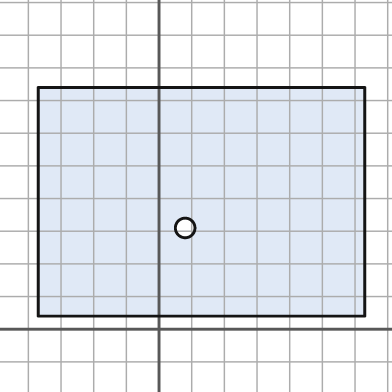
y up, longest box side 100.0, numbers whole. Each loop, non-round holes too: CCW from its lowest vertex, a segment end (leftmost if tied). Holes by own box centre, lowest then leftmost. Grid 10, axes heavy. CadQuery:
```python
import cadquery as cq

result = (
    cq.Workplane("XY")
    .moveTo(-37.0, 4.0)
    .lineTo(63.0, 4.0)
    .lineTo(63.0, 74.0)
    .lineTo(-37.0, 74.0)
    .close()
    .moveTo(8.0, 31.0)
    .circle(3.0)
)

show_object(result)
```